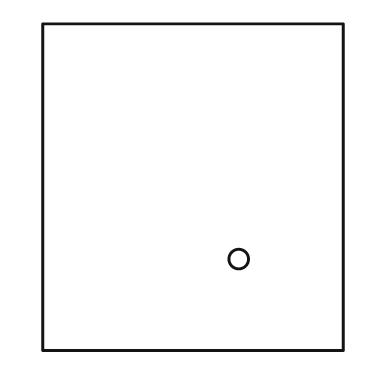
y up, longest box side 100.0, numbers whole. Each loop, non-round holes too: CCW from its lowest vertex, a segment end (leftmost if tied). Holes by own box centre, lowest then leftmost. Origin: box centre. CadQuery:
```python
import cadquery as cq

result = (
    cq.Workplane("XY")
    .moveTo(-46.0, -50.0)
    .lineTo(46.0, -50.0)
    .lineTo(46.0, 50.0)
    .lineTo(-46.0, 50.0)
    .close()
    .moveTo(14.0, -22.0)
    .circle(3.0)
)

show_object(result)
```